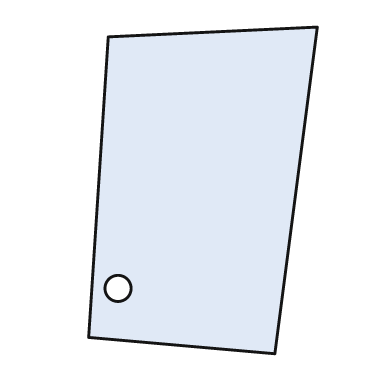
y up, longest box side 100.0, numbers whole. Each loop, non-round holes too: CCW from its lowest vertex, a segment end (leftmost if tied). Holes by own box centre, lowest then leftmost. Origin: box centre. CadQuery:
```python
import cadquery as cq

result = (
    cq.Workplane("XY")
    .moveTo(22.0, -50.0)
    .lineTo(35.0, 50.0)
    .lineTo(-29.0, 47.0)
    .lineTo(-35.0, -45.0)
    .close()
    .moveTo(-26.0, -30.0)
    .circle(4.0)
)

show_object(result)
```